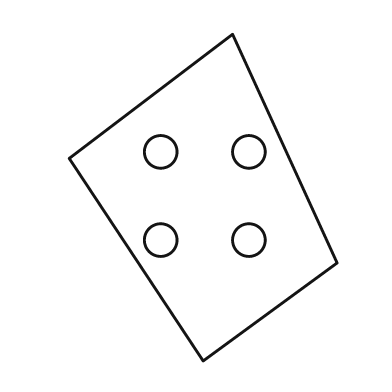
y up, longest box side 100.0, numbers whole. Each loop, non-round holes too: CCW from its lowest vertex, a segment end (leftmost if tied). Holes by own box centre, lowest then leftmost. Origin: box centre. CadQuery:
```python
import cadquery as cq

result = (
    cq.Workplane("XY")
    .moveTo(0.0, -50.0)
    .lineTo(41.0, -20.0)
    .lineTo(9.0, 50.0)
    .lineTo(-41.0, 12.0)
    .close()
    .moveTo(-13.0, -13.0)
    .circle(5.0)
    .moveTo(14.0, -13.0)
    .circle(5.0)
    .moveTo(-13.0, 14.0)
    .circle(5.0)
    .moveTo(14.0, 14.0)
    .circle(5.0)
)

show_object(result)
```